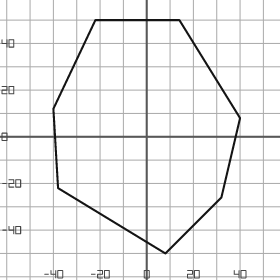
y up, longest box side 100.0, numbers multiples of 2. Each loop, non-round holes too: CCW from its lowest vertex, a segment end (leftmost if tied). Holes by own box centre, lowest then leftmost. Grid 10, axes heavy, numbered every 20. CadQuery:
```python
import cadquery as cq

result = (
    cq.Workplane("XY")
    .moveTo(8.0, -50.0)
    .lineTo(32.0, -26.0)
    .lineTo(40.0, 8.0)
    .lineTo(14.0, 50.0)
    .lineTo(-22.0, 50.0)
    .lineTo(-40.0, 12.0)
    .lineTo(-38.0, -22.0)
    .close()
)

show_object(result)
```